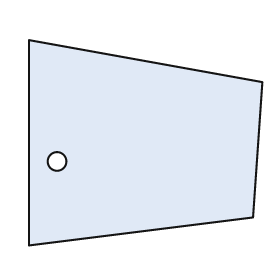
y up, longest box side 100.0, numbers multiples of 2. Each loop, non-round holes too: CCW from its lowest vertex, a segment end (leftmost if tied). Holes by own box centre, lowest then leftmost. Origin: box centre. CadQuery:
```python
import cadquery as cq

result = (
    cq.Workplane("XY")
    .moveTo(-50.0, -44.0)
    .lineTo(46.0, -32.0)
    .lineTo(50.0, 26.0)
    .lineTo(-50.0, 44.0)
    .close()
    .moveTo(-38.0, -8.0)
    .circle(4.0)
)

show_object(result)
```